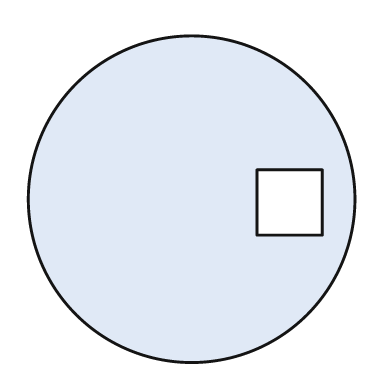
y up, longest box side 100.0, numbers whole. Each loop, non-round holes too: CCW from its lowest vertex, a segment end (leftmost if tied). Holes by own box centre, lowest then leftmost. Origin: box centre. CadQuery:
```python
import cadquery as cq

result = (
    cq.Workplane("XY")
    .moveTo(0.0, 0.0)
    .circle(50.0)
    .moveTo(20.0, -11.0)
    .lineTo(40.0, -11.0)
    .lineTo(40.0, 9.0)
    .lineTo(20.0, 9.0)
    .close()
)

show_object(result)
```